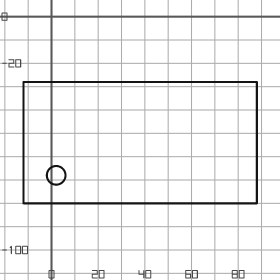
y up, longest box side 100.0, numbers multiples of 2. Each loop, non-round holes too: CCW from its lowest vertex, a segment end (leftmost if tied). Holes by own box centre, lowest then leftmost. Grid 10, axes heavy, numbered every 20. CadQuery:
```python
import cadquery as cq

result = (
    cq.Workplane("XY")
    .moveTo(-12.0, -80.0)
    .lineTo(88.0, -80.0)
    .lineTo(88.0, -28.0)
    .lineTo(-12.0, -28.0)
    .close()
    .moveTo(2.0, -68.0)
    .circle(4.0)
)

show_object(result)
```